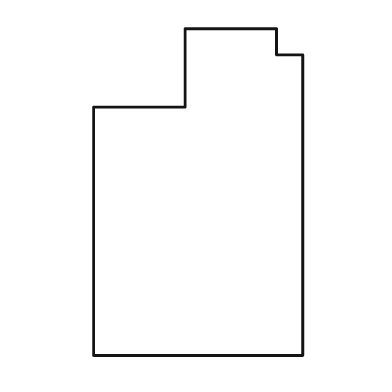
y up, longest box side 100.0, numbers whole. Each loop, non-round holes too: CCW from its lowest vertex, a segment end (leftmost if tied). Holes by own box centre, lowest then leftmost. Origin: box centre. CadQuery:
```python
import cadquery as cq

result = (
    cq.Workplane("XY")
    .moveTo(-32.0, -50.0)
    .lineTo(32.0, -50.0)
    .lineTo(32.0, 42.0)
    .lineTo(24.0, 42.0)
    .lineTo(24.0, 50.0)
    .lineTo(-4.0, 50.0)
    .lineTo(-4.0, 26.0)
    .lineTo(-32.0, 26.0)
    .close()
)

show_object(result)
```